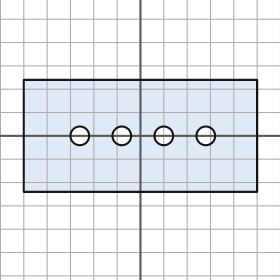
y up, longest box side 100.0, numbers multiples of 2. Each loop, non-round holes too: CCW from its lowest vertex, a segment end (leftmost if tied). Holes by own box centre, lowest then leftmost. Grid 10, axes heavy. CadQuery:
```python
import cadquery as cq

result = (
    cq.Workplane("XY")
    .moveTo(-50.0, -24.0)
    .lineTo(50.0, -24.0)
    .lineTo(50.0, 24.0)
    .lineTo(-50.0, 24.0)
    .close()
    .moveTo(-26.0, 0.0)
    .circle(4.0)
    .moveTo(-8.0, 0.0)
    .circle(4.0)
    .moveTo(10.0, 0.0)
    .circle(4.0)
    .moveTo(28.0, 0.0)
    .circle(4.0)
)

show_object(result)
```